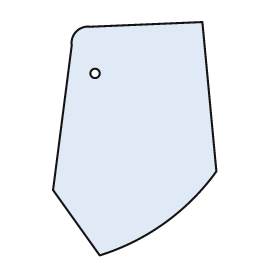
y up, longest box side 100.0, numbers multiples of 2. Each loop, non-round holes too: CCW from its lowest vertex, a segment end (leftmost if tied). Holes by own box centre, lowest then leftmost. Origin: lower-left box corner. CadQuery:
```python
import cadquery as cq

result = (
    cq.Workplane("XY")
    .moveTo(20.0, 0.0)
    .threePointArc((48.0, 14.0), (70.0, 36.0))
    .lineTo(64.0, 100.0)
    .lineTo(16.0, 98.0)
    .threePointArc((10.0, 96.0), (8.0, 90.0))
    .lineTo(0.0, 28.0)
    .close()
    .moveTo(18.0, 78.0)
    .circle(2.0)
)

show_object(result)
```